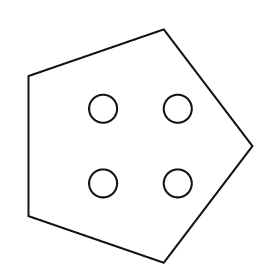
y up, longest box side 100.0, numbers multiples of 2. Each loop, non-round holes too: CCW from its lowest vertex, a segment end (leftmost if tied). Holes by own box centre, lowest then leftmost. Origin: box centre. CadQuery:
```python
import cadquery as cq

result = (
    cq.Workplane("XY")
    .moveTo(10.0, -50.0)
    .lineTo(48.0, 0.0)
    .lineTo(10.0, 50.0)
    .lineTo(-48.0, 30.0)
    .lineTo(-48.0, -30.0)
    .close()
    .moveTo(-16.0, -16.0)
    .circle(6.0)
    .moveTo(16.0, -16.0)
    .circle(6.0)
    .moveTo(-16.0, 16.0)
    .circle(6.0)
    .moveTo(16.0, 16.0)
    .circle(6.0)
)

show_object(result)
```